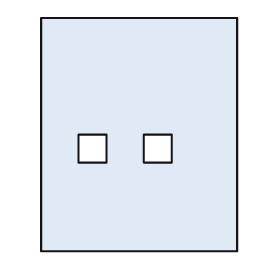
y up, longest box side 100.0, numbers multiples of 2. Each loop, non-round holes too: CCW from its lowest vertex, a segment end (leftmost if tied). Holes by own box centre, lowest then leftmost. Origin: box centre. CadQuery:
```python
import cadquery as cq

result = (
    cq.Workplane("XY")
    .moveTo(-42.0, -50.0)
    .lineTo(42.0, -50.0)
    .lineTo(42.0, 50.0)
    .lineTo(-42.0, 50.0)
    .close()
    .moveTo(-26.0, -12.0)
    .lineTo(-14.0, -12.0)
    .lineTo(-14.0, 0.0)
    .lineTo(-26.0, 0.0)
    .close()
    .moveTo(2.0, -12.0)
    .lineTo(14.0, -12.0)
    .lineTo(14.0, 0.0)
    .lineTo(2.0, 0.0)
    .close()
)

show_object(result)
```